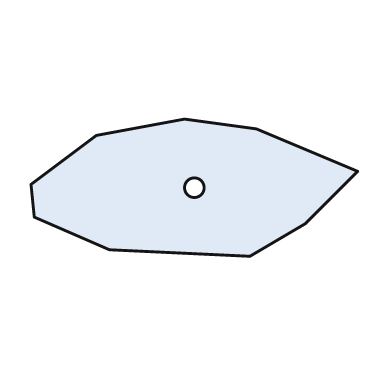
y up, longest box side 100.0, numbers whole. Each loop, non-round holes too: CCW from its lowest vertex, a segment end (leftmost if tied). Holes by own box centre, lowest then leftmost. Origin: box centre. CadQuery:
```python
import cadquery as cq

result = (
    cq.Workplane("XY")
    .moveTo(17.0, -21.0)
    .lineTo(34.0, -11.0)
    .lineTo(50.0, 5.0)
    .lineTo(19.0, 18.0)
    .lineTo(-3.0, 21.0)
    .lineTo(-30.0, 16.0)
    .lineTo(-50.0, 1.0)
    .lineTo(-49.0, -9.0)
    .lineTo(-26.0, -19.0)
    .close()
    .moveTo(0.0, 0.0)
    .circle(3.0)
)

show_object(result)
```